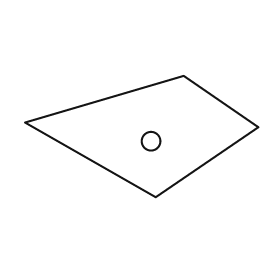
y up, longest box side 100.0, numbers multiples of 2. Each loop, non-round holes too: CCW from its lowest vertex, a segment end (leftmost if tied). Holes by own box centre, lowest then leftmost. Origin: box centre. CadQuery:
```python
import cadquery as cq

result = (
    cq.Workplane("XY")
    .moveTo(6.0, -26.0)
    .lineTo(50.0, 4.0)
    .lineTo(18.0, 26.0)
    .lineTo(-50.0, 6.0)
    .close()
    .moveTo(4.0, -2.0)
    .circle(4.0)
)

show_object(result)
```